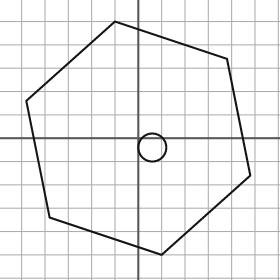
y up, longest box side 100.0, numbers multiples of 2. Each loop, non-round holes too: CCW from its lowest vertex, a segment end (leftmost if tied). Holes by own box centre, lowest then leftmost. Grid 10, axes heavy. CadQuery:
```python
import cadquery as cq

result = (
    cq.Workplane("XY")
    .moveTo(10.0, -50.0)
    .lineTo(48.0, -16.0)
    .lineTo(38.0, 34.0)
    .lineTo(-10.0, 50.0)
    .lineTo(-48.0, 16.0)
    .lineTo(-38.0, -34.0)
    .close()
    .moveTo(6.0, -4.0)
    .circle(6.0)
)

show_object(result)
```